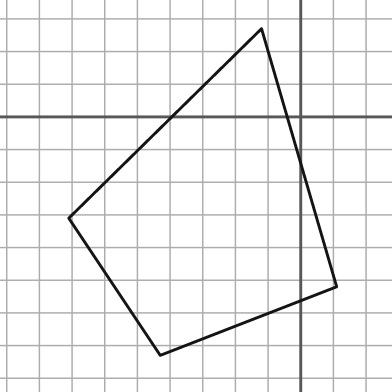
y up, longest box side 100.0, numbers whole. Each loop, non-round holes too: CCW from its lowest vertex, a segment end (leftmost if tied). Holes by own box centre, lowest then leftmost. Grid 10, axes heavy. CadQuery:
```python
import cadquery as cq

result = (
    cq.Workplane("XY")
    .moveTo(-43.0, -73.0)
    .lineTo(11.0, -52.0)
    .lineTo(-12.0, 27.0)
    .lineTo(-71.0, -31.0)
    .close()
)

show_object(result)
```